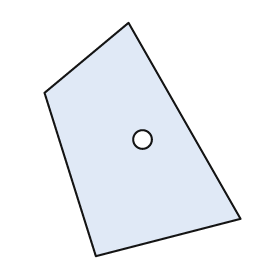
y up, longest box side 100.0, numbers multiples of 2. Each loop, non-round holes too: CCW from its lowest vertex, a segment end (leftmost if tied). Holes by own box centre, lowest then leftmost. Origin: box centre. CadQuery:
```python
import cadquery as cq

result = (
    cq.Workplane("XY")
    .moveTo(-20.0, -50.0)
    .lineTo(42.0, -34.0)
    .lineTo(-6.0, 50.0)
    .lineTo(-42.0, 20.0)
    .close()
    .moveTo(0.0, 0.0)
    .circle(4.0)
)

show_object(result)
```